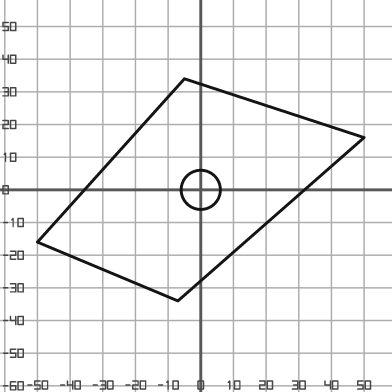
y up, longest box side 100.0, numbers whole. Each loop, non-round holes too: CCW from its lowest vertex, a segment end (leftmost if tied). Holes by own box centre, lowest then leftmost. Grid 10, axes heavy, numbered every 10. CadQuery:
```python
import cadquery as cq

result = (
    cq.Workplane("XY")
    .moveTo(-7.0, -34.0)
    .lineTo(50.0, 16.0)
    .lineTo(-5.0, 34.0)
    .lineTo(-50.0, -16.0)
    .close()
    .moveTo(0.0, 0.0)
    .circle(6.0)
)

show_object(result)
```